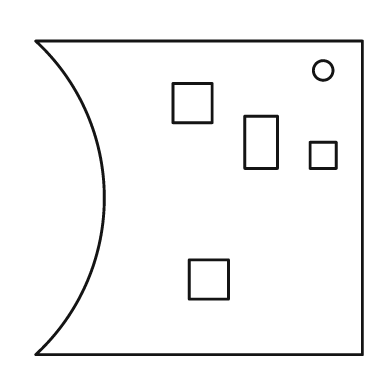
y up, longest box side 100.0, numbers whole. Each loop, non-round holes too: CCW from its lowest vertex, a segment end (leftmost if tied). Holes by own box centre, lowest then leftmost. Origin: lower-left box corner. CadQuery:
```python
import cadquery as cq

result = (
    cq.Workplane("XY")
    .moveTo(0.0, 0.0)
    .lineTo(100.0, 0.0)
    .lineTo(100.0, 96.0)
    .lineTo(0.0, 96.0)
    .threePointArc((21.0, 48.0), (0.0, 0.0))
    .close()
    .moveTo(47.0, 17.0)
    .lineTo(59.0, 17.0)
    .lineTo(59.0, 29.0)
    .lineTo(47.0, 29.0)
    .close()
    .moveTo(84.0, 57.0)
    .lineTo(92.0, 57.0)
    .lineTo(92.0, 65.0)
    .lineTo(84.0, 65.0)
    .close()
    .moveTo(64.0, 57.0)
    .lineTo(74.0, 57.0)
    .lineTo(74.0, 73.0)
    .lineTo(64.0, 73.0)
    .close()
    .moveTo(42.0, 71.0)
    .lineTo(54.0, 71.0)
    .lineTo(54.0, 83.0)
    .lineTo(42.0, 83.0)
    .close()
    .moveTo(88.0, 87.0)
    .circle(3.0)
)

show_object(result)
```